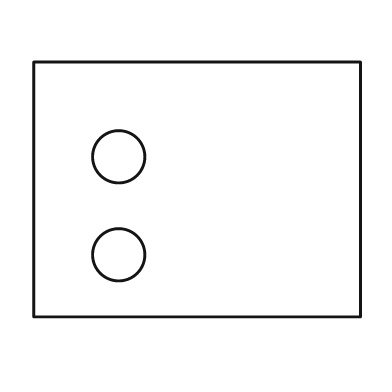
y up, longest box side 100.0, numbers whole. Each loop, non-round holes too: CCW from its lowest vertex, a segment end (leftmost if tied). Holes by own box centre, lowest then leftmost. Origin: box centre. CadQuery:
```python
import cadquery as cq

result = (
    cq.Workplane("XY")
    .moveTo(-50.0, -39.0)
    .lineTo(50.0, -39.0)
    .lineTo(50.0, 39.0)
    .lineTo(-50.0, 39.0)
    .close()
    .moveTo(-24.0, -20.0)
    .circle(8.0)
    .moveTo(-24.0, 10.0)
    .circle(8.0)
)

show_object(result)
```